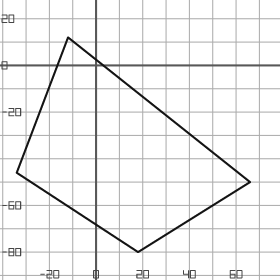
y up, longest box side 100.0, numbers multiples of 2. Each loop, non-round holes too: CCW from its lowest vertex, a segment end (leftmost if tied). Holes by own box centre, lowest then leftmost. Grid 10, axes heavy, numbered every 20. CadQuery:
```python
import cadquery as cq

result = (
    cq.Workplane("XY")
    .moveTo(18.0, -80.0)
    .lineTo(66.0, -50.0)
    .lineTo(-12.0, 12.0)
    .lineTo(-34.0, -46.0)
    .close()
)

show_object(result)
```